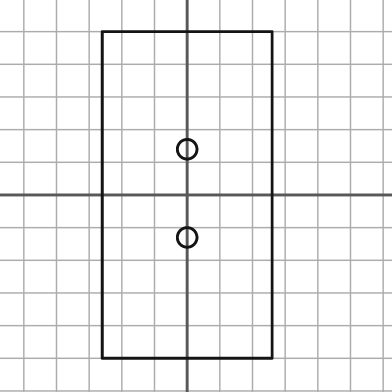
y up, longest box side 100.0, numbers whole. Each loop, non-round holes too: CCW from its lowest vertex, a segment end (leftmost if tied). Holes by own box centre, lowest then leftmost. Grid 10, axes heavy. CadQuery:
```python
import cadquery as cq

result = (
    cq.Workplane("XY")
    .moveTo(-26.0, -50.0)
    .lineTo(26.0, -50.0)
    .lineTo(26.0, 50.0)
    .lineTo(-26.0, 50.0)
    .close()
    .moveTo(0.0, -13.0)
    .circle(3.0)
    .moveTo(0.0, 14.0)
    .circle(3.0)
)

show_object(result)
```